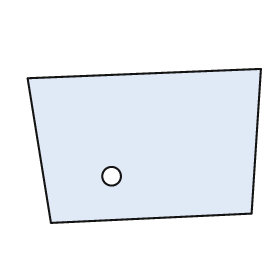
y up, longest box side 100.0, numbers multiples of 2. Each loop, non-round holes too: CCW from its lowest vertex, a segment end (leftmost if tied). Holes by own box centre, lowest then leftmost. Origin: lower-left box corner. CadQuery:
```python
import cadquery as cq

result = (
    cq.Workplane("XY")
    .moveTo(10.0, 0.0)
    .lineTo(96.0, 4.0)
    .lineTo(100.0, 66.0)
    .lineTo(0.0, 62.0)
    .close()
    .moveTo(36.0, 20.0)
    .circle(4.0)
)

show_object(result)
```